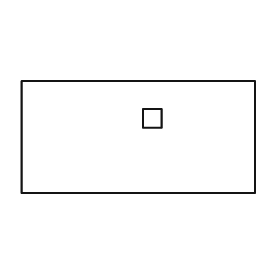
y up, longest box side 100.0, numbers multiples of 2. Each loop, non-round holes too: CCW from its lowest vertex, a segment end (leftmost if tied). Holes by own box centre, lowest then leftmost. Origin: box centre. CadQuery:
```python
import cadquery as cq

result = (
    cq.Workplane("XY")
    .moveTo(-50.0, -24.0)
    .lineTo(50.0, -24.0)
    .lineTo(50.0, 24.0)
    .lineTo(-50.0, 24.0)
    .close()
    .moveTo(2.0, 4.0)
    .lineTo(10.0, 4.0)
    .lineTo(10.0, 12.0)
    .lineTo(2.0, 12.0)
    .close()
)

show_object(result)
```